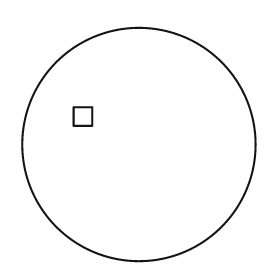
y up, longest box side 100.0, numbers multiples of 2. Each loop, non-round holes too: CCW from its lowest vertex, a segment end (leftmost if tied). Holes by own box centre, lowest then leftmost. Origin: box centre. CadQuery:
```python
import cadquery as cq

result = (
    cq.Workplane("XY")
    .moveTo(0.0, 0.0)
    .circle(50.0)
    .moveTo(-28.0, 8.0)
    .lineTo(-20.0, 8.0)
    .lineTo(-20.0, 16.0)
    .lineTo(-28.0, 16.0)
    .close()
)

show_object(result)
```